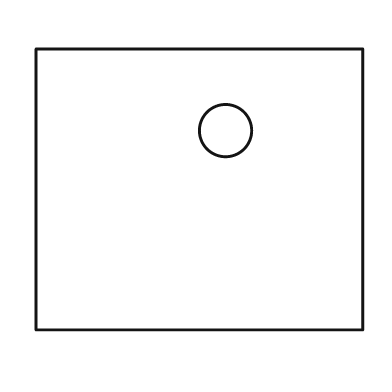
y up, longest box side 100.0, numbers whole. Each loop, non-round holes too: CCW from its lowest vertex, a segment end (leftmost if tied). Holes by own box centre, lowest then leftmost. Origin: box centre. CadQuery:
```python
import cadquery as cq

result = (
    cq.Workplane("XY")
    .moveTo(-50.0, -43.0)
    .lineTo(50.0, -43.0)
    .lineTo(50.0, 43.0)
    .lineTo(-50.0, 43.0)
    .close()
    .moveTo(8.0, 18.0)
    .circle(8.0)
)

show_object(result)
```